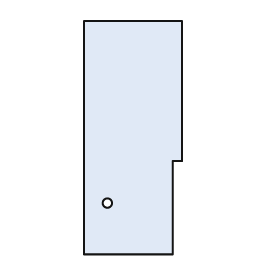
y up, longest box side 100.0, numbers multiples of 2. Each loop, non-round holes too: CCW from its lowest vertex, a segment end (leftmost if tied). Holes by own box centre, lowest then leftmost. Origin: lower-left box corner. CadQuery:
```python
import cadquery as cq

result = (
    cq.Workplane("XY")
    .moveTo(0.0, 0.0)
    .lineTo(38.0, 0.0)
    .lineTo(38.0, 40.0)
    .lineTo(42.0, 40.0)
    .lineTo(42.0, 100.0)
    .lineTo(0.0, 100.0)
    .close()
    .moveTo(10.0, 22.0)
    .circle(2.0)
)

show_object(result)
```